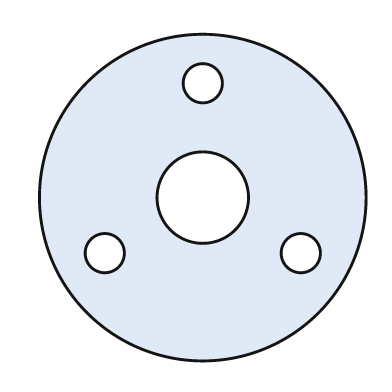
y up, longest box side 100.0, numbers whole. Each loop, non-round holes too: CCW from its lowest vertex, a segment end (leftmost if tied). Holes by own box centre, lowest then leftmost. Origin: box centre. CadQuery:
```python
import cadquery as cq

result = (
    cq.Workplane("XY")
    .moveTo(0.0, 0.0)
    .circle(50.0)
    .moveTo(-30.0, -17.0)
    .circle(6.0)
    .moveTo(30.0, -17.0)
    .circle(6.0)
    .moveTo(0.0, 0.0)
    .circle(14.0)
    .moveTo(0.0, 35.0)
    .circle(6.0)
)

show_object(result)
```